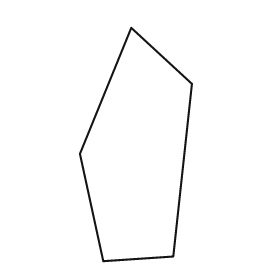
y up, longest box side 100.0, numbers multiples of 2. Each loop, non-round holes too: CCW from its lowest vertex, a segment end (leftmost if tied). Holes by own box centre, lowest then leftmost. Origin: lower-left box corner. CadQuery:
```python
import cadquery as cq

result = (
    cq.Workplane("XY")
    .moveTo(10.0, 0.0)
    .lineTo(40.0, 2.0)
    .lineTo(48.0, 76.0)
    .lineTo(22.0, 100.0)
    .lineTo(0.0, 46.0)
    .close()
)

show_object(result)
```